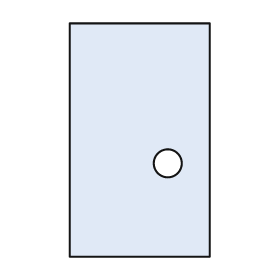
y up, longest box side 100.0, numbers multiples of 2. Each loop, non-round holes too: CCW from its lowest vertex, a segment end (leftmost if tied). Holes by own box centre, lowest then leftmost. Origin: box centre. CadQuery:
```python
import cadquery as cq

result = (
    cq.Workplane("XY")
    .moveTo(-30.0, -50.0)
    .lineTo(30.0, -50.0)
    .lineTo(30.0, 50.0)
    .lineTo(-30.0, 50.0)
    .close()
    .moveTo(12.0, -10.0)
    .circle(6.0)
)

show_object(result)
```